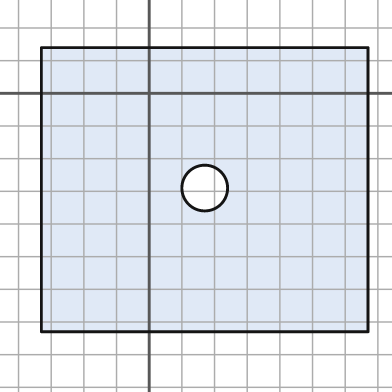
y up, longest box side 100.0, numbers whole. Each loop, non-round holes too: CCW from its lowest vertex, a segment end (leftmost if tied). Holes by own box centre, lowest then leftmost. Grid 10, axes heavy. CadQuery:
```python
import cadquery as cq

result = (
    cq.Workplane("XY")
    .moveTo(-33.0, -73.0)
    .lineTo(67.0, -73.0)
    .lineTo(67.0, 14.0)
    .lineTo(-33.0, 14.0)
    .close()
    .moveTo(17.0, -29.0)
    .circle(7.0)
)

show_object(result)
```